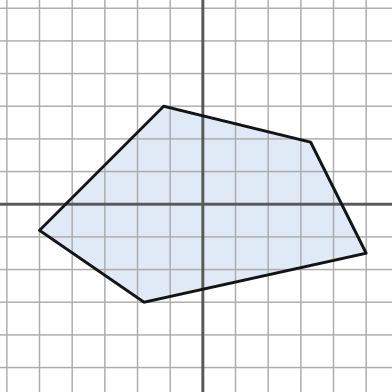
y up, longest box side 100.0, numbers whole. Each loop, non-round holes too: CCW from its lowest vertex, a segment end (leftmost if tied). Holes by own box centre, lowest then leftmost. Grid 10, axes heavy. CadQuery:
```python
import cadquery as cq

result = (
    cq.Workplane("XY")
    .moveTo(-18.0, -30.0)
    .lineTo(50.0, -15.0)
    .lineTo(33.0, 19.0)
    .lineTo(-12.0, 30.0)
    .lineTo(-50.0, -8.0)
    .close()
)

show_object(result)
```